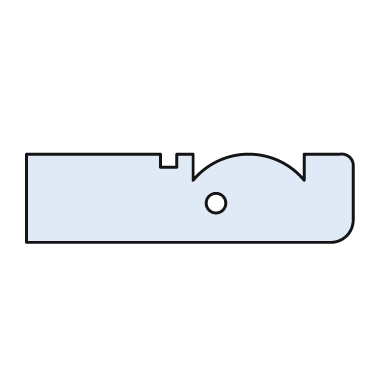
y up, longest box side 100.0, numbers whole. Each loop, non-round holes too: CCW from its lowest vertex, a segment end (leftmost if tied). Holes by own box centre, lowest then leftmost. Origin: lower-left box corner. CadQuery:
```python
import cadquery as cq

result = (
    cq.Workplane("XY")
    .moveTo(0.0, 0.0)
    .lineTo(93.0, 0.0)
    .threePointArc((98.0, 2.0), (100.0, 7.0))
    .lineTo(100.0, 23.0)
    .threePointArc((99.0, 26.0), (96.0, 27.0))
    .lineTo(85.0, 27.0)
    .lineTo(85.0, 19.0)
    .threePointArc((68.0, 27.0), (51.0, 19.0))
    .lineTo(51.0, 27.0)
    .lineTo(46.0, 27.0)
    .lineTo(46.0, 23.0)
    .lineTo(41.0, 23.0)
    .lineTo(41.0, 27.0)
    .lineTo(0.0, 27.0)
    .close()
    .moveTo(58.0, 12.0)
    .circle(3.0)
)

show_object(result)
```